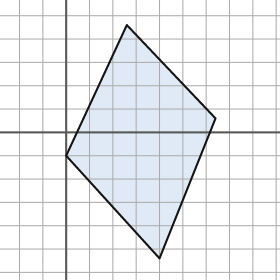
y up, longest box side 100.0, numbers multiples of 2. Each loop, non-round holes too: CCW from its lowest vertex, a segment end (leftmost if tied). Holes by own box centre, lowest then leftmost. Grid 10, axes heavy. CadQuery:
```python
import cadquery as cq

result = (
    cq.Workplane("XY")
    .moveTo(40.0, -54.0)
    .lineTo(64.0, 6.0)
    .lineTo(26.0, 46.0)
    .lineTo(0.0, -10.0)
    .close()
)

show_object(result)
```